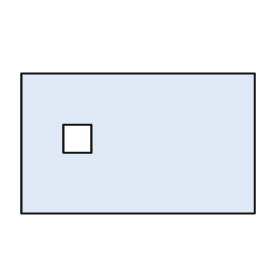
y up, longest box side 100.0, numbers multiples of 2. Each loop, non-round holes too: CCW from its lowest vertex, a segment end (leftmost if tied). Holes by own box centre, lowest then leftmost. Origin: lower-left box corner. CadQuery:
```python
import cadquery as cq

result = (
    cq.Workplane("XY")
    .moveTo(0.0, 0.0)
    .lineTo(100.0, 0.0)
    .lineTo(100.0, 60.0)
    .lineTo(0.0, 60.0)
    .close()
    .moveTo(18.0, 26.0)
    .lineTo(30.0, 26.0)
    .lineTo(30.0, 38.0)
    .lineTo(18.0, 38.0)
    .close()
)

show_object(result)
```